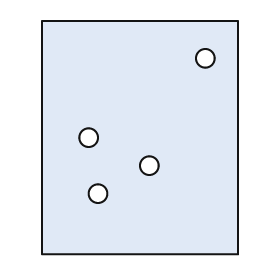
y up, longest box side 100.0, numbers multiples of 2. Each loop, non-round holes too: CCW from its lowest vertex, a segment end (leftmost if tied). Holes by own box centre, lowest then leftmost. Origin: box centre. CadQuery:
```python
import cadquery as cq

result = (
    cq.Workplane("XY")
    .moveTo(-42.0, -50.0)
    .lineTo(42.0, -50.0)
    .lineTo(42.0, 50.0)
    .lineTo(-42.0, 50.0)
    .close()
    .moveTo(-18.0, -24.0)
    .circle(4.0)
    .moveTo(4.0, -12.0)
    .circle(4.0)
    .moveTo(-22.0, 0.0)
    .circle(4.0)
    .moveTo(28.0, 34.0)
    .circle(4.0)
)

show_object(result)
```